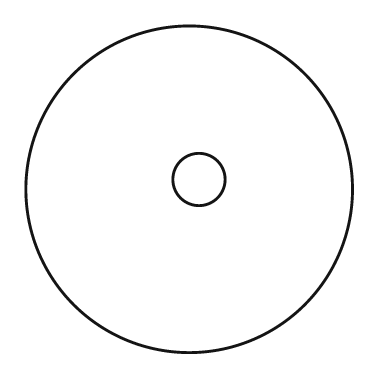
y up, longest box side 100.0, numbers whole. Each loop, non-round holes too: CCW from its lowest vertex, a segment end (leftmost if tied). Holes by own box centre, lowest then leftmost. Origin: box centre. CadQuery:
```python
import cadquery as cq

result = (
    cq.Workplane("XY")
    .moveTo(0.0, 0.0)
    .circle(50.0)
    .moveTo(3.0, 3.0)
    .circle(8.0)
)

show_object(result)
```